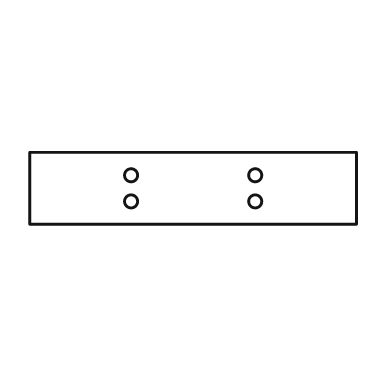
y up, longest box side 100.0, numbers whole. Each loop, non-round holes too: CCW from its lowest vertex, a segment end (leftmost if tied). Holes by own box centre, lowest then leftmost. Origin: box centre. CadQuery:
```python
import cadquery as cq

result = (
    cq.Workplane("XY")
    .moveTo(-50.0, -11.0)
    .lineTo(50.0, -11.0)
    .lineTo(50.0, 11.0)
    .lineTo(-50.0, 11.0)
    .close()
    .moveTo(-19.0, -4.0)
    .circle(2.0)
    .moveTo(19.0, -4.0)
    .circle(2.0)
    .moveTo(-19.0, 4.0)
    .circle(2.0)
    .moveTo(19.0, 4.0)
    .circle(2.0)
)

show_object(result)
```